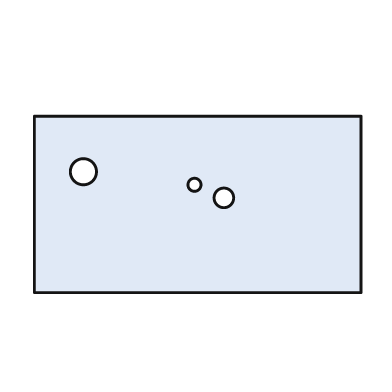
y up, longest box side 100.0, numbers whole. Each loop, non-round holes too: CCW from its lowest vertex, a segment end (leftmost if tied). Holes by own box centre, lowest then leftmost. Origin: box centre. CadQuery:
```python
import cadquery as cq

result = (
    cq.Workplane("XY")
    .moveTo(-50.0, -27.0)
    .lineTo(50.0, -27.0)
    .lineTo(50.0, 27.0)
    .lineTo(-50.0, 27.0)
    .close()
    .moveTo(8.0, 2.0)
    .circle(3.0)
    .moveTo(-1.0, 6.0)
    .circle(2.0)
    .moveTo(-35.0, 10.0)
    .circle(4.0)
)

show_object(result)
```